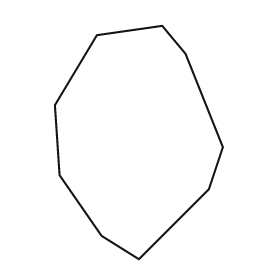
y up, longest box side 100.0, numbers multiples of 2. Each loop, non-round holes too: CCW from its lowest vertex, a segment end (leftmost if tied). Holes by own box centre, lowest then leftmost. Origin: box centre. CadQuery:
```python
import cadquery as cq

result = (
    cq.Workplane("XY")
    .moveTo(0.0, -50.0)
    .lineTo(30.0, -20.0)
    .lineTo(36.0, -2.0)
    .lineTo(20.0, 38.0)
    .lineTo(10.0, 50.0)
    .lineTo(-18.0, 46.0)
    .lineTo(-36.0, 16.0)
    .lineTo(-34.0, -14.0)
    .lineTo(-16.0, -40.0)
    .close()
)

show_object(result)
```